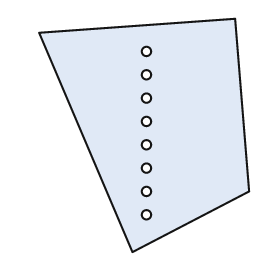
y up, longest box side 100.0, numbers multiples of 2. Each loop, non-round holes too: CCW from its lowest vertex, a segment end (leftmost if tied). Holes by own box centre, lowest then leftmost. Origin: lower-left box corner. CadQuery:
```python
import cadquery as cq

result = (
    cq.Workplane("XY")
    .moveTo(40.0, 0.0)
    .lineTo(90.0, 26.0)
    .lineTo(84.0, 100.0)
    .lineTo(0.0, 94.0)
    .close()
    .moveTo(46.0, 16.0)
    .circle(2.0)
    .moveTo(46.0, 26.0)
    .circle(2.0)
    .moveTo(46.0, 36.0)
    .circle(2.0)
    .moveTo(46.0, 46.0)
    .circle(2.0)
    .moveTo(46.0, 56.0)
    .circle(2.0)
    .moveTo(46.0, 66.0)
    .circle(2.0)
    .moveTo(46.0, 76.0)
    .circle(2.0)
    .moveTo(46.0, 86.0)
    .circle(2.0)
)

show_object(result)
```